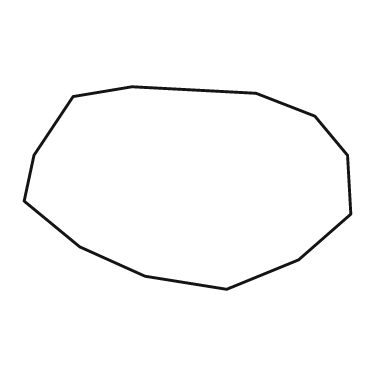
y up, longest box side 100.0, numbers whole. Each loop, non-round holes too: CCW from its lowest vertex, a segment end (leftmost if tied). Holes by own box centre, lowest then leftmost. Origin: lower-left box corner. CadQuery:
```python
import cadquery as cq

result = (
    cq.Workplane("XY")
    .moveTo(62.0, 0.0)
    .lineTo(84.0, 9.0)
    .lineTo(100.0, 23.0)
    .lineTo(99.0, 41.0)
    .lineTo(89.0, 53.0)
    .lineTo(71.0, 60.0)
    .lineTo(33.0, 62.0)
    .lineTo(15.0, 59.0)
    .lineTo(3.0, 41.0)
    .lineTo(0.0, 27.0)
    .lineTo(17.0, 13.0)
    .lineTo(37.0, 4.0)
    .close()
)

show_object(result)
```